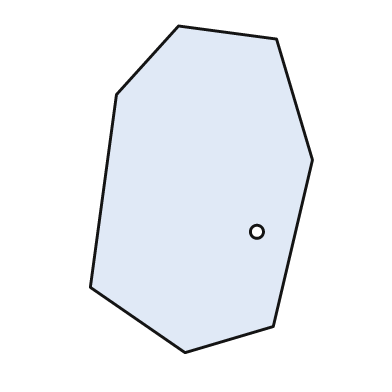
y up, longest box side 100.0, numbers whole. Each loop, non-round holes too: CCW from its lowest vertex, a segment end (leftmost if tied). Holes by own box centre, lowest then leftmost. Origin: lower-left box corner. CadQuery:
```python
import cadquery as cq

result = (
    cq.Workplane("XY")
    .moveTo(29.0, 0.0)
    .lineTo(56.0, 8.0)
    .lineTo(68.0, 59.0)
    .lineTo(57.0, 96.0)
    .lineTo(27.0, 100.0)
    .lineTo(8.0, 79.0)
    .lineTo(0.0, 20.0)
    .close()
    .moveTo(51.0, 37.0)
    .circle(2.0)
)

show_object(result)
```